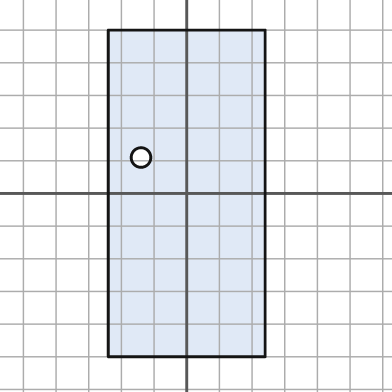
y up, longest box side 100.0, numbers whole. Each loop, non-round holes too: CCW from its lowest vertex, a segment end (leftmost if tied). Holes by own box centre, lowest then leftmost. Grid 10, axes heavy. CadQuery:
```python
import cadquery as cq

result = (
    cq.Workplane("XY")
    .moveTo(-24.0, -50.0)
    .lineTo(24.0, -50.0)
    .lineTo(24.0, 50.0)
    .lineTo(-24.0, 50.0)
    .close()
    .moveTo(-14.0, 11.0)
    .circle(3.0)
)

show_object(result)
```